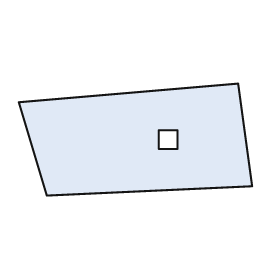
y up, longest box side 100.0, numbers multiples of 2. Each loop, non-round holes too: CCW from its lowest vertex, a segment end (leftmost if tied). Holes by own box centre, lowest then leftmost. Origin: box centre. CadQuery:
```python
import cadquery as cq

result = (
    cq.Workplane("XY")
    .moveTo(-38.0, -24.0)
    .lineTo(50.0, -20.0)
    .lineTo(44.0, 24.0)
    .lineTo(-50.0, 16.0)
    .close()
    .moveTo(10.0, -4.0)
    .lineTo(18.0, -4.0)
    .lineTo(18.0, 4.0)
    .lineTo(10.0, 4.0)
    .close()
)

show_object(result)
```